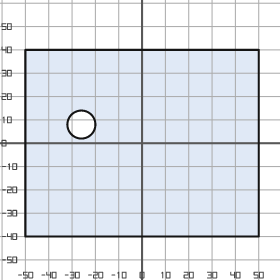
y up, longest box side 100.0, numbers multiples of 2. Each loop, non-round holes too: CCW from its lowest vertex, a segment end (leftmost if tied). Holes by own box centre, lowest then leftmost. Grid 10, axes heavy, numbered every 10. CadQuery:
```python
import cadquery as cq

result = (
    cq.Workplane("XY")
    .moveTo(-50.0, -40.0)
    .lineTo(50.0, -40.0)
    .lineTo(50.0, 40.0)
    .lineTo(-50.0, 40.0)
    .close()
    .moveTo(-26.0, 8.0)
    .circle(6.0)
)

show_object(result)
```